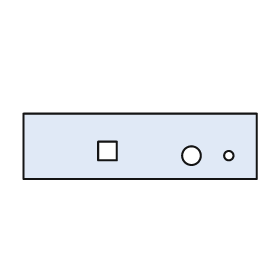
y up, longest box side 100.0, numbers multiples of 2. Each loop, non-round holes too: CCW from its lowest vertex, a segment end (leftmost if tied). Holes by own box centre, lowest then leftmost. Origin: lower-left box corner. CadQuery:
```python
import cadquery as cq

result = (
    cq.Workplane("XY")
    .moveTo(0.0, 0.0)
    .lineTo(100.0, 0.0)
    .lineTo(100.0, 28.0)
    .lineTo(0.0, 28.0)
    .close()
    .moveTo(72.0, 10.0)
    .circle(4.0)
    .moveTo(88.0, 10.0)
    .circle(2.0)
    .moveTo(32.0, 8.0)
    .lineTo(40.0, 8.0)
    .lineTo(40.0, 16.0)
    .lineTo(32.0, 16.0)
    .close()
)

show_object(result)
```